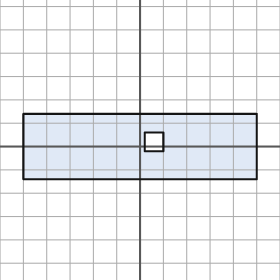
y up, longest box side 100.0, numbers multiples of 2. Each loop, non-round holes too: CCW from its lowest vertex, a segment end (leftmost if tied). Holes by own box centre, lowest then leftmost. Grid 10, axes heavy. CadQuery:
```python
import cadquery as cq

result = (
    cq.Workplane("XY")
    .moveTo(-50.0, -14.0)
    .lineTo(50.0, -14.0)
    .lineTo(50.0, 14.0)
    .lineTo(-50.0, 14.0)
    .close()
    .moveTo(2.0, -2.0)
    .lineTo(10.0, -2.0)
    .lineTo(10.0, 6.0)
    .lineTo(2.0, 6.0)
    .close()
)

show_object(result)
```